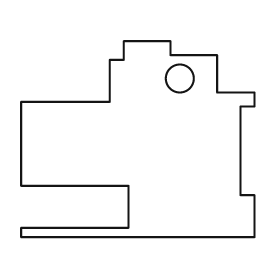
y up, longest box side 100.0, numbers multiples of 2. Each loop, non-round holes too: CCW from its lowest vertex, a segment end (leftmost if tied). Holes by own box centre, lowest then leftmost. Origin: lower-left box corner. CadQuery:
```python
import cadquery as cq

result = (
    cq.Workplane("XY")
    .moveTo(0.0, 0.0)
    .lineTo(100.0, 0.0)
    .lineTo(100.0, 18.0)
    .lineTo(94.0, 18.0)
    .lineTo(94.0, 56.0)
    .lineTo(100.0, 56.0)
    .lineTo(100.0, 62.0)
    .lineTo(84.0, 62.0)
    .lineTo(84.0, 78.0)
    .lineTo(64.0, 78.0)
    .lineTo(64.0, 84.0)
    .lineTo(44.0, 84.0)
    .lineTo(44.0, 76.0)
    .lineTo(38.0, 76.0)
    .lineTo(38.0, 58.0)
    .lineTo(0.0, 58.0)
    .lineTo(0.0, 22.0)
    .lineTo(46.0, 22.0)
    .lineTo(46.0, 4.0)
    .lineTo(0.0, 4.0)
    .close()
    .moveTo(68.0, 68.0)
    .circle(6.0)
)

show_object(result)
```